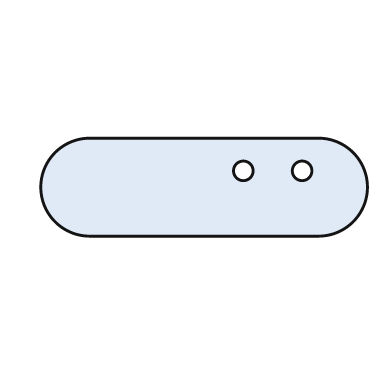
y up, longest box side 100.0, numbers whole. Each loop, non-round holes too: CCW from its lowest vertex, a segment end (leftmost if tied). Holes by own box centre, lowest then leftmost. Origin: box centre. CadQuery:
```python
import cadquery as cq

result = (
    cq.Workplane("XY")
    .moveTo(-35.0, -15.0)
    .lineTo(35.0, -15.0)
    .threePointArc((50.0, 0.0), (35.0, 15.0))
    .lineTo(-35.0, 15.0)
    .threePointArc((-50.0, 0.0), (-35.0, -15.0))
    .close()
    .moveTo(12.0, 5.0)
    .circle(3.0)
    .moveTo(30.0, 5.0)
    .circle(3.0)
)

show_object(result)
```